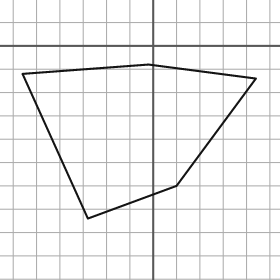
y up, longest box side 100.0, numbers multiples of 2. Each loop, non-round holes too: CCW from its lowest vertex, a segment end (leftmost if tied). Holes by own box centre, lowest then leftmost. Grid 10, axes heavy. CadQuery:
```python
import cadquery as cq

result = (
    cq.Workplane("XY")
    .moveTo(-28.0, -74.0)
    .lineTo(10.0, -60.0)
    .lineTo(44.0, -14.0)
    .lineTo(-2.0, -8.0)
    .lineTo(-56.0, -12.0)
    .close()
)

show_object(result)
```